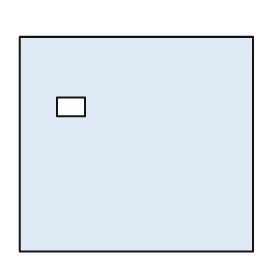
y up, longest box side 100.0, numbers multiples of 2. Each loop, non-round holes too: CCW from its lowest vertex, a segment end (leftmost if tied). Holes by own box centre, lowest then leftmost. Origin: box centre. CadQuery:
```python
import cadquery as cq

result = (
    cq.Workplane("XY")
    .moveTo(-50.0, -46.0)
    .lineTo(50.0, -46.0)
    .lineTo(50.0, 46.0)
    .lineTo(-50.0, 46.0)
    .close()
    .moveTo(-34.0, 12.0)
    .lineTo(-22.0, 12.0)
    .lineTo(-22.0, 20.0)
    .lineTo(-34.0, 20.0)
    .close()
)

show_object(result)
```